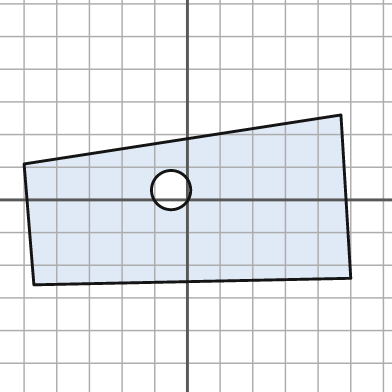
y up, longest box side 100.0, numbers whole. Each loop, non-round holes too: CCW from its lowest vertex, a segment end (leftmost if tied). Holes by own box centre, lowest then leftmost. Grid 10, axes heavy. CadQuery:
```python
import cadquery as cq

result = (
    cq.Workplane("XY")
    .moveTo(-47.0, -26.0)
    .lineTo(50.0, -24.0)
    .lineTo(47.0, 26.0)
    .lineTo(-50.0, 11.0)
    .close()
    .moveTo(-5.0, 3.0)
    .circle(6.0)
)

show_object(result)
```